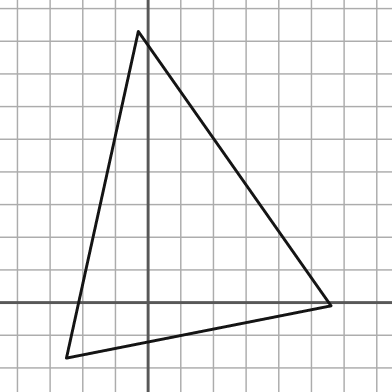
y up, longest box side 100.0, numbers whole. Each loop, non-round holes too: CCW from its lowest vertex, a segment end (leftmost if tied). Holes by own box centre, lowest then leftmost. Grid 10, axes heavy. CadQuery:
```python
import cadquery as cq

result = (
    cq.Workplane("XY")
    .moveTo(-25.0, -17.0)
    .lineTo(56.0, -1.0)
    .lineTo(-3.0, 83.0)
    .close()
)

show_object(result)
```